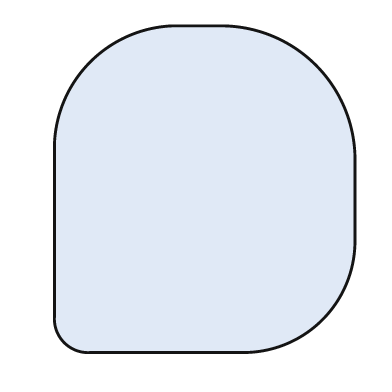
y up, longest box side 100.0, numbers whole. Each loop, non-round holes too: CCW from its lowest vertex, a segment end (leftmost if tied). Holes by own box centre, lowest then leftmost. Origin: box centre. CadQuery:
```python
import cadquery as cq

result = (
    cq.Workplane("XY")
    .moveTo(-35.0, -50.0)
    .lineTo(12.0, -50.0)
    .threePointArc((36.0, -40.0), (46.0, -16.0))
    .lineTo(46.0, 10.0)
    .threePointArc((34.0, 38.0), (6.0, 50.0))
    .lineTo(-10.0, 50.0)
    .threePointArc((-35.0, 39.0), (-46.0, 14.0))
    .lineTo(-46.0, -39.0)
    .threePointArc((-43.0, -47.0), (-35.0, -50.0))
    .close()
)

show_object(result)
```